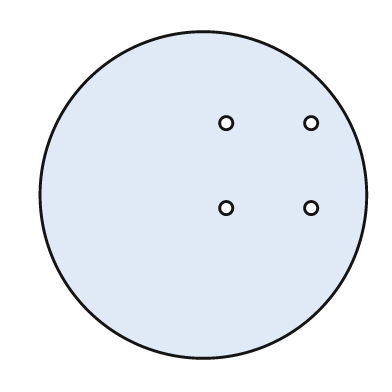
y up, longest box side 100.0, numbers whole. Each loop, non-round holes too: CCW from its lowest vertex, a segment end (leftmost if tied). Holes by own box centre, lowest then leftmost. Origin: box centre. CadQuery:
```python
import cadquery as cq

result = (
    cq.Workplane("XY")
    .moveTo(0.0, 0.0)
    .circle(50.0)
    .moveTo(7.0, -4.0)
    .circle(2.0)
    .moveTo(33.0, -4.0)
    .circle(2.0)
    .moveTo(7.0, 22.0)
    .circle(2.0)
    .moveTo(33.0, 22.0)
    .circle(2.0)
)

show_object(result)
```